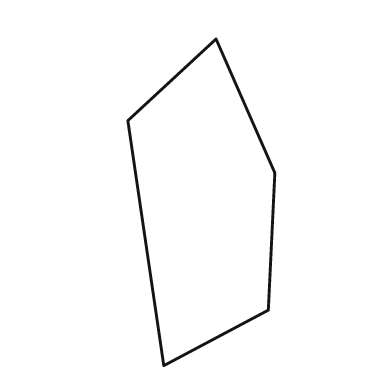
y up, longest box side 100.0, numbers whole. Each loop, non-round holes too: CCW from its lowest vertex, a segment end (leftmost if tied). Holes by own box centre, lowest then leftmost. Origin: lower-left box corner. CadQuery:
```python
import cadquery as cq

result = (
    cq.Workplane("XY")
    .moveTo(11.0, 0.0)
    .lineTo(43.0, 17.0)
    .lineTo(45.0, 59.0)
    .lineTo(27.0, 100.0)
    .lineTo(0.0, 75.0)
    .close()
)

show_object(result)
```